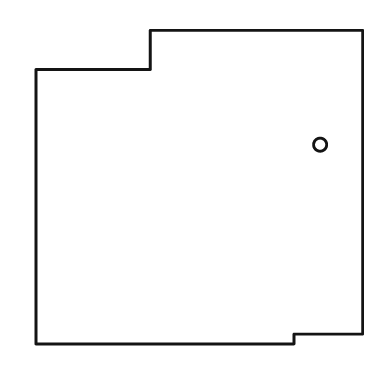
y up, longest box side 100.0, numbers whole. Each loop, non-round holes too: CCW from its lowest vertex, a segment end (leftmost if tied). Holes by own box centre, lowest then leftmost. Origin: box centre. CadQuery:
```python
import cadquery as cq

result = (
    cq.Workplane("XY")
    .moveTo(-50.0, -48.0)
    .lineTo(29.0, -48.0)
    .lineTo(29.0, -45.0)
    .lineTo(50.0, -45.0)
    .lineTo(50.0, 48.0)
    .lineTo(-15.0, 48.0)
    .lineTo(-15.0, 36.0)
    .lineTo(-50.0, 36.0)
    .close()
    .moveTo(37.0, 13.0)
    .circle(2.0)
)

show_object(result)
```